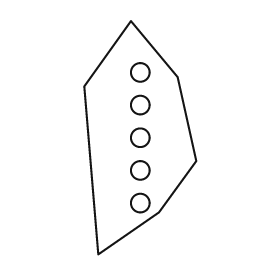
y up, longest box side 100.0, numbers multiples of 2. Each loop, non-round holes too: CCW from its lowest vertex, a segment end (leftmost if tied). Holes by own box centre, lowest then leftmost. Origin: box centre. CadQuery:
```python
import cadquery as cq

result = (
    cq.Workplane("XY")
    .moveTo(-18.0, -50.0)
    .lineTo(8.0, -32.0)
    .lineTo(24.0, -10.0)
    .lineTo(16.0, 26.0)
    .lineTo(-4.0, 50.0)
    .lineTo(-24.0, 22.0)
    .close()
    .moveTo(0.0, -28.0)
    .circle(4.0)
    .moveTo(0.0, -14.0)
    .circle(4.0)
    .moveTo(0.0, 0.0)
    .circle(4.0)
    .moveTo(0.0, 14.0)
    .circle(4.0)
    .moveTo(0.0, 28.0)
    .circle(4.0)
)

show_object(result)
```